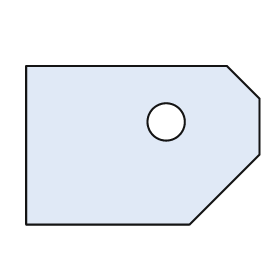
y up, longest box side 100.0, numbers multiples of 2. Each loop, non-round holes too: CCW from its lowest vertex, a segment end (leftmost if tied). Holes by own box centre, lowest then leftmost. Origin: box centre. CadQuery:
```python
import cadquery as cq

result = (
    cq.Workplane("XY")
    .moveTo(-50.0, -34.0)
    .lineTo(20.0, -34.0)
    .lineTo(50.0, -4.0)
    .lineTo(50.0, 20.0)
    .lineTo(36.0, 34.0)
    .lineTo(-50.0, 34.0)
    .close()
    .moveTo(10.0, 10.0)
    .circle(8.0)
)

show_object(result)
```